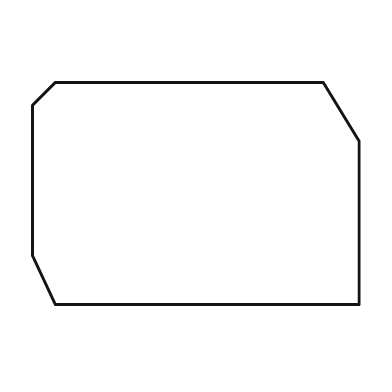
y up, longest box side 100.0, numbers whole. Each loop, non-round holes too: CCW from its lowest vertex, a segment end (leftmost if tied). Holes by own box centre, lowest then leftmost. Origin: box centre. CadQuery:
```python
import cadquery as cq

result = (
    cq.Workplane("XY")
    .moveTo(-43.0, -34.0)
    .lineTo(50.0, -34.0)
    .lineTo(50.0, 16.0)
    .lineTo(39.0, 34.0)
    .lineTo(-43.0, 34.0)
    .lineTo(-50.0, 27.0)
    .lineTo(-50.0, -19.0)
    .close()
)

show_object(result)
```